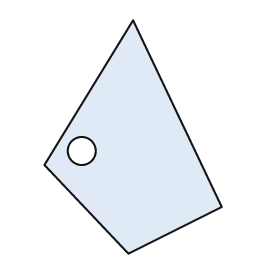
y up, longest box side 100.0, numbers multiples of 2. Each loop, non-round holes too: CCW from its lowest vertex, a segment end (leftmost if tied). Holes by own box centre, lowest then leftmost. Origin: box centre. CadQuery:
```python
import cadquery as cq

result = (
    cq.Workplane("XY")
    .moveTo(-2.0, -50.0)
    .lineTo(38.0, -30.0)
    .lineTo(0.0, 50.0)
    .lineTo(-38.0, -12.0)
    .close()
    .moveTo(-22.0, -6.0)
    .circle(6.0)
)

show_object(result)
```